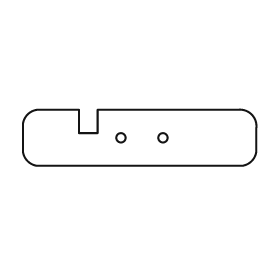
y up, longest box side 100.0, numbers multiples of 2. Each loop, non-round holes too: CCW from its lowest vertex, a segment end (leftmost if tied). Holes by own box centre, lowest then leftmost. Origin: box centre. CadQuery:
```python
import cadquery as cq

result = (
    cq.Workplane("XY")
    .moveTo(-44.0, -12.0)
    .lineTo(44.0, -12.0)
    .threePointArc((48.0, -10.0), (50.0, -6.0))
    .lineTo(50.0, 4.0)
    .threePointArc((48.0, 10.0), (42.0, 12.0))
    .lineTo(-18.0, 12.0)
    .lineTo(-18.0, 2.0)
    .lineTo(-26.0, 2.0)
    .lineTo(-26.0, 12.0)
    .lineTo(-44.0, 12.0)
    .threePointArc((-48.0, 10.0), (-50.0, 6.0))
    .lineTo(-50.0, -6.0)
    .threePointArc((-48.0, -10.0), (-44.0, -12.0))
    .close()
    .moveTo(-8.0, 0.0)
    .circle(2.0)
    .moveTo(10.0, 0.0)
    .circle(2.0)
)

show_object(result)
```